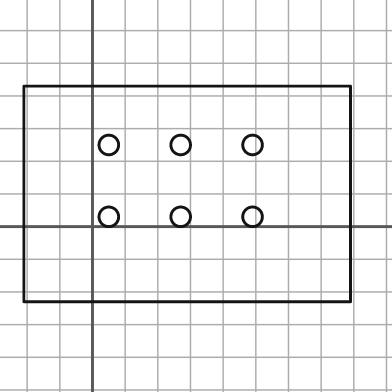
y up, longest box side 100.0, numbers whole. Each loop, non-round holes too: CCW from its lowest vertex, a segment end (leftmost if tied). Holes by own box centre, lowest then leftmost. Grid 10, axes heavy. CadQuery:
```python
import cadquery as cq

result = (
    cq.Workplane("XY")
    .moveTo(-21.0, -23.0)
    .lineTo(79.0, -23.0)
    .lineTo(79.0, 43.0)
    .lineTo(-21.0, 43.0)
    .close()
    .moveTo(5.0, 3.0)
    .circle(3.0)
    .moveTo(27.0, 3.0)
    .circle(3.0)
    .moveTo(49.0, 3.0)
    .circle(3.0)
    .moveTo(5.0, 25.0)
    .circle(3.0)
    .moveTo(27.0, 25.0)
    .circle(3.0)
    .moveTo(49.0, 25.0)
    .circle(3.0)
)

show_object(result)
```